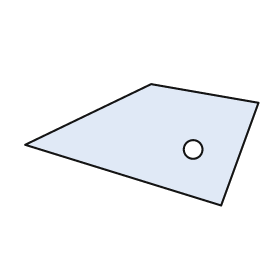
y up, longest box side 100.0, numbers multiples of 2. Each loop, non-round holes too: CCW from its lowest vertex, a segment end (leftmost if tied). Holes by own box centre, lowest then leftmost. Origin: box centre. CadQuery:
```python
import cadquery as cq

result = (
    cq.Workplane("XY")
    .moveTo(34.0, -26.0)
    .lineTo(50.0, 18.0)
    .lineTo(4.0, 26.0)
    .lineTo(-50.0, 0.0)
    .close()
    .moveTo(22.0, -2.0)
    .circle(4.0)
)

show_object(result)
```